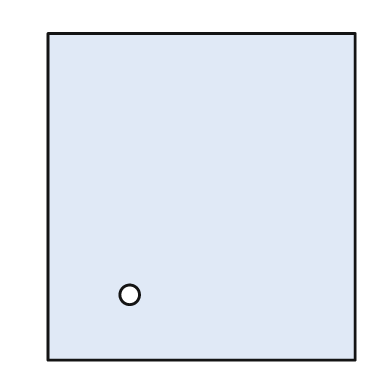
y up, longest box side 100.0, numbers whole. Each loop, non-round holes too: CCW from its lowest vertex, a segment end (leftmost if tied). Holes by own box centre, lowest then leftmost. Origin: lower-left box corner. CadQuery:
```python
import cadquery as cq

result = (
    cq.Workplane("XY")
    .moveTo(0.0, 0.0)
    .lineTo(94.0, 0.0)
    .lineTo(94.0, 100.0)
    .lineTo(0.0, 100.0)
    .close()
    .moveTo(25.0, 20.0)
    .circle(3.0)
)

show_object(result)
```